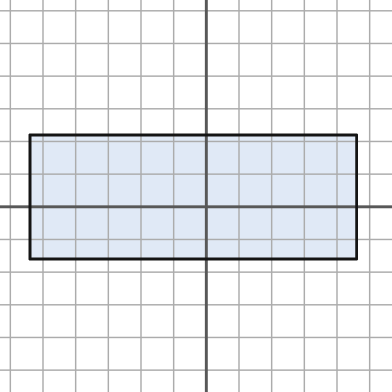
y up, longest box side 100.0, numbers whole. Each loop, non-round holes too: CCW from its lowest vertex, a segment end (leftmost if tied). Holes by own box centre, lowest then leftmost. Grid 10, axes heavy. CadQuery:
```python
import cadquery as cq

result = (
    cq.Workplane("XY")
    .moveTo(-54.0, -16.0)
    .lineTo(46.0, -16.0)
    .lineTo(46.0, 22.0)
    .lineTo(-54.0, 22.0)
    .close()
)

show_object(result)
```